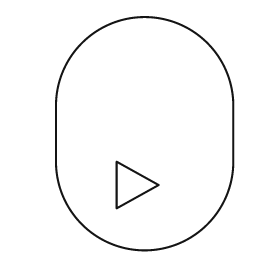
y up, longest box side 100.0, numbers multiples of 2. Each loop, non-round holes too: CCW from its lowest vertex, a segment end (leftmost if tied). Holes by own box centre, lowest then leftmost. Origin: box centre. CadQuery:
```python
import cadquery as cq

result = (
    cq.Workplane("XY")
    .moveTo(-38.0, -12.0)
    .threePointArc((0.0, -50.0), (38.0, -12.0))
    .lineTo(38.0, 12.0)
    .threePointArc((0.0, 50.0), (-38.0, 12.0))
    .close()
    .moveTo(-12.0, -32.0)
    .lineTo(6.0, -22.0)
    .lineTo(-12.0, -12.0)
    .close()
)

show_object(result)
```